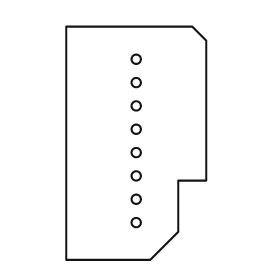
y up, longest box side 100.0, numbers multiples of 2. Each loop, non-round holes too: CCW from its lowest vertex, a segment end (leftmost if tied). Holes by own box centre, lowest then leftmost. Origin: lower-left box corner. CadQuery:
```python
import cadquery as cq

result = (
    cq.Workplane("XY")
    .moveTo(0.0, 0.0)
    .lineTo(36.0, 0.0)
    .lineTo(48.0, 12.0)
    .lineTo(48.0, 34.0)
    .lineTo(60.0, 34.0)
    .lineTo(60.0, 94.0)
    .lineTo(54.0, 100.0)
    .lineTo(0.0, 100.0)
    .close()
    .moveTo(30.0, 16.0)
    .circle(2.0)
    .moveTo(30.0, 26.0)
    .circle(2.0)
    .moveTo(30.0, 36.0)
    .circle(2.0)
    .moveTo(30.0, 46.0)
    .circle(2.0)
    .moveTo(30.0, 56.0)
    .circle(2.0)
    .moveTo(30.0, 66.0)
    .circle(2.0)
    .moveTo(30.0, 76.0)
    .circle(2.0)
    .moveTo(30.0, 86.0)
    .circle(2.0)
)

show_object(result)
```